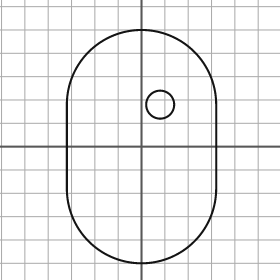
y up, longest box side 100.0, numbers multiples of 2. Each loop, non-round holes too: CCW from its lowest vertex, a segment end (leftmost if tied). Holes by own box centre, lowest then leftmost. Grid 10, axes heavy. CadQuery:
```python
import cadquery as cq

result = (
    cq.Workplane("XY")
    .moveTo(-32.0, -18.0)
    .threePointArc((0.0, -50.0), (32.0, -18.0))
    .lineTo(32.0, 18.0)
    .threePointArc((0.0, 50.0), (-32.0, 18.0))
    .close()
    .moveTo(8.0, 18.0)
    .circle(6.0)
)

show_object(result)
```